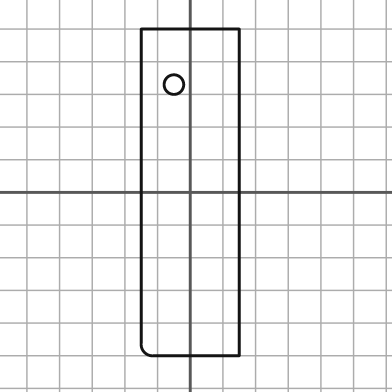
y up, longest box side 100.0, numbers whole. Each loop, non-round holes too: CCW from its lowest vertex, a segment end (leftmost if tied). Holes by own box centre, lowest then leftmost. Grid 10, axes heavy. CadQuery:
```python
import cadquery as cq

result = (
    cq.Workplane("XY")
    .moveTo(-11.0, -50.0)
    .lineTo(15.0, -50.0)
    .lineTo(15.0, 50.0)
    .lineTo(-15.0, 50.0)
    .lineTo(-15.0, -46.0)
    .threePointArc((-14.0, -49.0), (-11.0, -50.0))
    .close()
    .moveTo(-5.0, 33.0)
    .circle(3.0)
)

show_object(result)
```